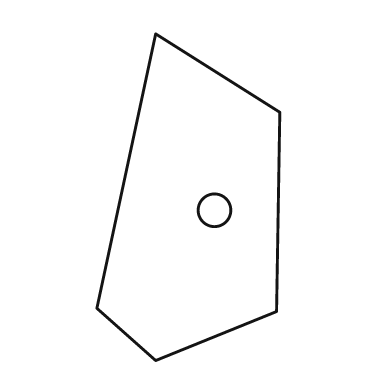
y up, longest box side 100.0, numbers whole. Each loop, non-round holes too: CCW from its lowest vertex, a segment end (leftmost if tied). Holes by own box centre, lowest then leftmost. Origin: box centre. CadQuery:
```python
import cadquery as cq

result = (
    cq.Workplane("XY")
    .moveTo(-10.0, -50.0)
    .lineTo(27.0, -35.0)
    .lineTo(28.0, 26.0)
    .lineTo(-10.0, 50.0)
    .lineTo(-28.0, -34.0)
    .close()
    .moveTo(8.0, -4.0)
    .circle(5.0)
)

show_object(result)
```